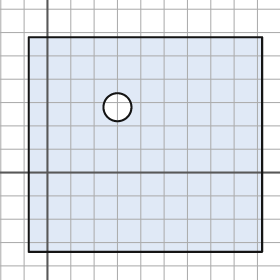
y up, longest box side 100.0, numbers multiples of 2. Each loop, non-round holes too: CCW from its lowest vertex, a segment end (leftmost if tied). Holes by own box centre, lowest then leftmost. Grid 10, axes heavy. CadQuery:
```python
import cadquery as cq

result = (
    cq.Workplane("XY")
    .moveTo(-8.0, -34.0)
    .lineTo(92.0, -34.0)
    .lineTo(92.0, 58.0)
    .lineTo(-8.0, 58.0)
    .close()
    .moveTo(30.0, 28.0)
    .circle(6.0)
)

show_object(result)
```